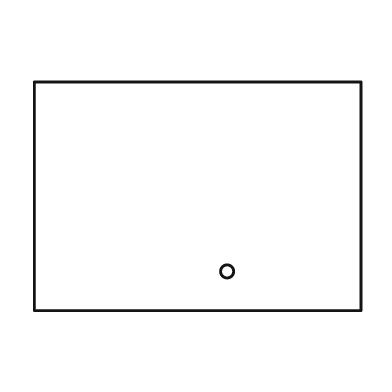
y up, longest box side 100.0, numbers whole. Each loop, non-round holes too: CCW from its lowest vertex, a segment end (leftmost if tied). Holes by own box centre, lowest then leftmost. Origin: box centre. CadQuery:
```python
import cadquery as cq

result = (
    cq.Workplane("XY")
    .moveTo(-50.0, -35.0)
    .lineTo(50.0, -35.0)
    .lineTo(50.0, 35.0)
    .lineTo(-50.0, 35.0)
    .close()
    .moveTo(9.0, -23.0)
    .circle(2.0)
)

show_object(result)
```